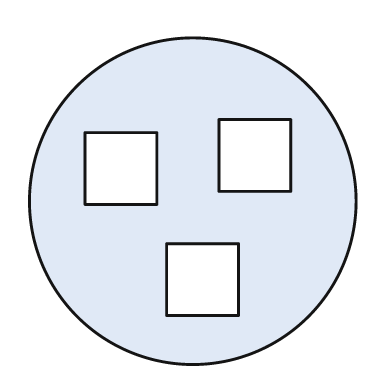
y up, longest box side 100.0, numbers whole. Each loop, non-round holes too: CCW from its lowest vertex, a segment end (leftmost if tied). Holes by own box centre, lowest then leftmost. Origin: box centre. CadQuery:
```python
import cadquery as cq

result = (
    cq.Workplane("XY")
    .moveTo(0.0, 0.0)
    .circle(50.0)
    .moveTo(-8.0, -35.0)
    .lineTo(14.0, -35.0)
    .lineTo(14.0, -13.0)
    .lineTo(-8.0, -13.0)
    .close()
    .moveTo(-33.0, -1.0)
    .lineTo(-11.0, -1.0)
    .lineTo(-11.0, 21.0)
    .lineTo(-33.0, 21.0)
    .close()
    .moveTo(8.0, 3.0)
    .lineTo(30.0, 3.0)
    .lineTo(30.0, 25.0)
    .lineTo(8.0, 25.0)
    .close()
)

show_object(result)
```